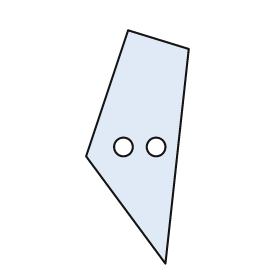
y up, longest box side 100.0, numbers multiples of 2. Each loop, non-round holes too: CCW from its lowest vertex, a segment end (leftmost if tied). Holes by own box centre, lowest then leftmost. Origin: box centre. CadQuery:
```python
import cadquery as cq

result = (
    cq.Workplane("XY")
    .moveTo(12.0, -50.0)
    .lineTo(22.0, 42.0)
    .lineTo(-4.0, 50.0)
    .lineTo(-22.0, -4.0)
    .close()
    .moveTo(-6.0, 0.0)
    .circle(4.0)
    .moveTo(8.0, 0.0)
    .circle(4.0)
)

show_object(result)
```